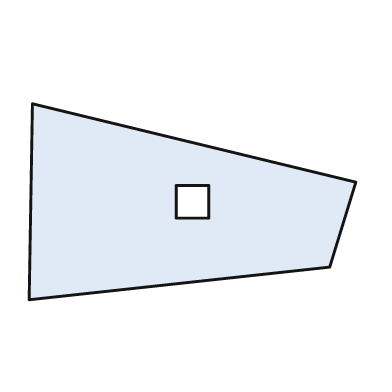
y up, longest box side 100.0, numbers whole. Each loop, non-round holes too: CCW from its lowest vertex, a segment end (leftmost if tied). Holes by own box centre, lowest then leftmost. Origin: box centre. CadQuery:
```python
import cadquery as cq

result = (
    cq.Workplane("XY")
    .moveTo(-50.0, -30.0)
    .lineTo(42.0, -20.0)
    .lineTo(50.0, 6.0)
    .lineTo(-49.0, 30.0)
    .close()
    .moveTo(-5.0, -5.0)
    .lineTo(5.0, -5.0)
    .lineTo(5.0, 5.0)
    .lineTo(-5.0, 5.0)
    .close()
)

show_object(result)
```